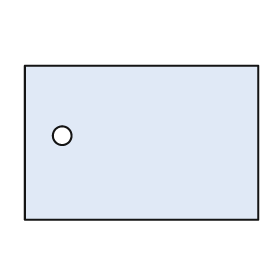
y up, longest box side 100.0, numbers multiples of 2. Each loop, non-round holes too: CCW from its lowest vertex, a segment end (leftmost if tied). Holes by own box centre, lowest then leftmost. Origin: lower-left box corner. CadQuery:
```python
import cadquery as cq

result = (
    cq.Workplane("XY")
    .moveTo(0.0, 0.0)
    .lineTo(100.0, 0.0)
    .lineTo(100.0, 66.0)
    .lineTo(0.0, 66.0)
    .close()
    .moveTo(16.0, 36.0)
    .circle(4.0)
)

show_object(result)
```